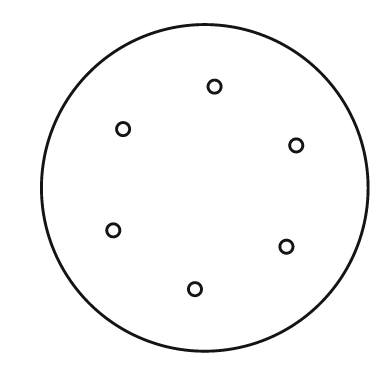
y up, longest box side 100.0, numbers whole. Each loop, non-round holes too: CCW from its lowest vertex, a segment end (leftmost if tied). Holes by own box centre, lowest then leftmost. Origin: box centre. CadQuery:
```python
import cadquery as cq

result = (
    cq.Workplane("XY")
    .moveTo(0.0, 0.0)
    .circle(50.0)
    .moveTo(-3.0, -31.0)
    .circle(2.0)
    .moveTo(25.0, -18.0)
    .circle(2.0)
    .moveTo(-28.0, -13.0)
    .circle(2.0)
    .moveTo(28.0, 13.0)
    .circle(2.0)
    .moveTo(-25.0, 18.0)
    .circle(2.0)
    .moveTo(3.0, 31.0)
    .circle(2.0)
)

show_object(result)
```